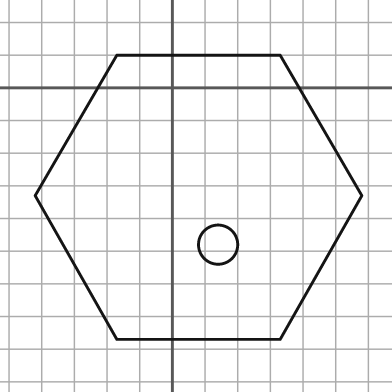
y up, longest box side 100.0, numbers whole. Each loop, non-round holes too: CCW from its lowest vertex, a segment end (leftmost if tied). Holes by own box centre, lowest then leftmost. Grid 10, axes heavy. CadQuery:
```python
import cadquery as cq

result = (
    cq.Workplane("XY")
    .moveTo(-17.0, -77.0)
    .lineTo(33.0, -77.0)
    .lineTo(58.0, -33.0)
    .lineTo(33.0, 10.0)
    .lineTo(-17.0, 10.0)
    .lineTo(-42.0, -33.0)
    .close()
    .moveTo(14.0, -48.0)
    .circle(6.0)
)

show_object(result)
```